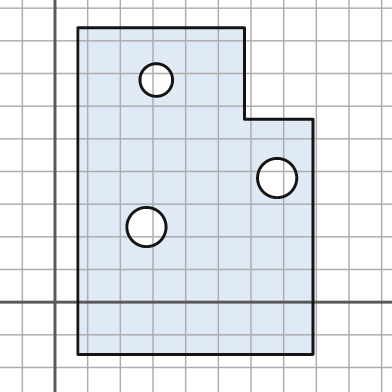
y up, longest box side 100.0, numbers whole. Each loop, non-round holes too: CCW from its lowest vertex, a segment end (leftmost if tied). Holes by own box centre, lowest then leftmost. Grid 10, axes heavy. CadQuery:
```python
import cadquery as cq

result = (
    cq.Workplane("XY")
    .moveTo(7.0, -16.0)
    .lineTo(79.0, -16.0)
    .lineTo(79.0, 56.0)
    .lineTo(58.0, 56.0)
    .lineTo(58.0, 84.0)
    .lineTo(7.0, 84.0)
    .close()
    .moveTo(28.0, 23.0)
    .circle(6.0)
    .moveTo(68.0, 38.0)
    .circle(6.0)
    .moveTo(31.0, 68.0)
    .circle(5.0)
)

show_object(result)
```